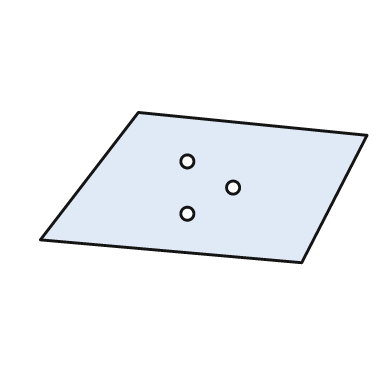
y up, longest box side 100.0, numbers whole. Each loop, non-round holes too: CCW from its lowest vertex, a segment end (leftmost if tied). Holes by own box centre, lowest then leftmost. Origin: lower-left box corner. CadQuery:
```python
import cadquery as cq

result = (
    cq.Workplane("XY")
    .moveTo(80.0, 0.0)
    .lineTo(100.0, 39.0)
    .lineTo(30.0, 46.0)
    .lineTo(0.0, 7.0)
    .close()
    .moveTo(45.0, 15.0)
    .circle(2.0)
    .moveTo(59.0, 23.0)
    .circle(2.0)
    .moveTo(45.0, 31.0)
    .circle(2.0)
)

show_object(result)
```